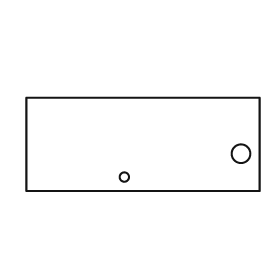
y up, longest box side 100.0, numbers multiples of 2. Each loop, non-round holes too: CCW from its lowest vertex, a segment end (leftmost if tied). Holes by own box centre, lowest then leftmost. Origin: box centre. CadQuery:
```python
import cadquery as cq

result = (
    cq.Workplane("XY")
    .moveTo(-50.0, -20.0)
    .lineTo(50.0, -20.0)
    .lineTo(50.0, 20.0)
    .lineTo(-50.0, 20.0)
    .close()
    .moveTo(-8.0, -14.0)
    .circle(2.0)
    .moveTo(42.0, -4.0)
    .circle(4.0)
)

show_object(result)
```